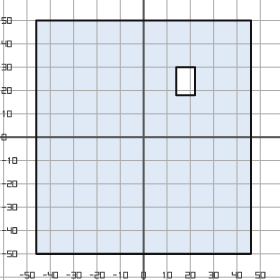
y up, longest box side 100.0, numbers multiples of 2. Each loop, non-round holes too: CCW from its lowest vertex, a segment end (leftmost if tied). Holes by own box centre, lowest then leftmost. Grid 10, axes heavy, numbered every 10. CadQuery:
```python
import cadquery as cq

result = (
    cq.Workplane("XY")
    .moveTo(-46.0, -50.0)
    .lineTo(46.0, -50.0)
    .lineTo(46.0, 50.0)
    .lineTo(-46.0, 50.0)
    .close()
    .moveTo(14.0, 18.0)
    .lineTo(22.0, 18.0)
    .lineTo(22.0, 30.0)
    .lineTo(14.0, 30.0)
    .close()
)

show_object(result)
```